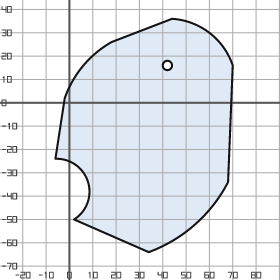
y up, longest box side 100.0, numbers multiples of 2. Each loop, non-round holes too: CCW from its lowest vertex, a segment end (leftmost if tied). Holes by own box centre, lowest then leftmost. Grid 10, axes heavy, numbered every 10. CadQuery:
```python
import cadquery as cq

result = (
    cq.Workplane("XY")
    .moveTo(34.0, -64.0)
    .threePointArc((54.0, -52.0), (68.0, -34.0))
    .lineTo(70.0, 16.0)
    .threePointArc((60.0, 30.0), (44.0, 36.0))
    .lineTo(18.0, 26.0)
    .threePointArc((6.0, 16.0), (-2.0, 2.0))
    .lineTo(-6.0, -24.0)
    .threePointArc((8.0, -34.0), (2.0, -50.0))
    .close()
    .moveTo(42.0, 16.0)
    .circle(2.0)
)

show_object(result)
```